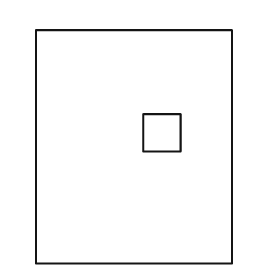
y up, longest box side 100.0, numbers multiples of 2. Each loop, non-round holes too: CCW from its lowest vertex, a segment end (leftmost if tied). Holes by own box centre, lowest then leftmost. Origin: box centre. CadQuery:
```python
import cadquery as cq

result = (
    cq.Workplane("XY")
    .moveTo(-42.0, -50.0)
    .lineTo(42.0, -50.0)
    .lineTo(42.0, 50.0)
    .lineTo(-42.0, 50.0)
    .close()
    .moveTo(4.0, -2.0)
    .lineTo(20.0, -2.0)
    .lineTo(20.0, 14.0)
    .lineTo(4.0, 14.0)
    .close()
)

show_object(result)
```